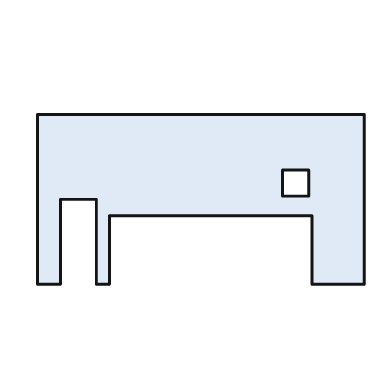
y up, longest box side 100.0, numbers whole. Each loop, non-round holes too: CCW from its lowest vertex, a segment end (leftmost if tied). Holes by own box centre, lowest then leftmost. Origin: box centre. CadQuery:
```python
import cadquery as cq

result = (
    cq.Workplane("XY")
    .moveTo(-50.0, -26.0)
    .lineTo(-43.0, -26.0)
    .lineTo(-43.0, 0.0)
    .lineTo(-32.0, 0.0)
    .lineTo(-32.0, -26.0)
    .lineTo(-28.0, -26.0)
    .lineTo(-28.0, -5.0)
    .lineTo(34.0, -5.0)
    .lineTo(34.0, -26.0)
    .lineTo(50.0, -26.0)
    .lineTo(50.0, 26.0)
    .lineTo(-50.0, 26.0)
    .close()
    .moveTo(25.0, 1.0)
    .lineTo(33.0, 1.0)
    .lineTo(33.0, 9.0)
    .lineTo(25.0, 9.0)
    .close()
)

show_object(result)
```